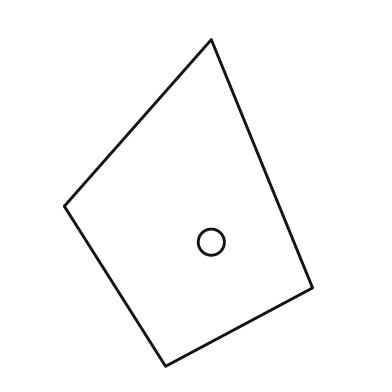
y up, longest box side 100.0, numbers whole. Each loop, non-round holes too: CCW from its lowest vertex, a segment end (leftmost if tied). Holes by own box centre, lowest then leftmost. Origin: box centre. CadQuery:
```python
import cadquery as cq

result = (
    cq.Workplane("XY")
    .moveTo(-7.0, -50.0)
    .lineTo(38.0, -26.0)
    .lineTo(7.0, 50.0)
    .lineTo(-38.0, -1.0)
    .close()
    .moveTo(7.0, -12.0)
    .circle(4.0)
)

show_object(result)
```